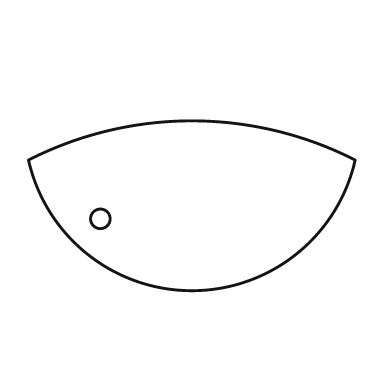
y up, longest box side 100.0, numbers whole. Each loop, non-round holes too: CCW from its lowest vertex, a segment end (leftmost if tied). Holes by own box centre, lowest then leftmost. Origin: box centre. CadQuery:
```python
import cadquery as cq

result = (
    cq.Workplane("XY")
    .moveTo(-50.0, 14.0)
    .threePointArc((0.0, -26.0), (50.0, 14.0))
    .threePointArc((0.0, 26.0), (-50.0, 14.0))
    .close()
    .moveTo(-28.0, -4.0)
    .circle(3.0)
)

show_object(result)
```